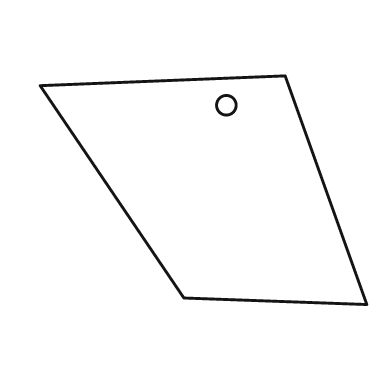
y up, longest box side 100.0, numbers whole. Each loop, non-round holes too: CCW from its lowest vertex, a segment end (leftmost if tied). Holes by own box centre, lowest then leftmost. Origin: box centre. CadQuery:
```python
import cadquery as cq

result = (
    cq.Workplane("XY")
    .moveTo(50.0, -35.0)
    .lineTo(25.0, 35.0)
    .lineTo(-50.0, 32.0)
    .lineTo(-6.0, -33.0)
    .close()
    .moveTo(7.0, 26.0)
    .circle(3.0)
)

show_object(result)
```